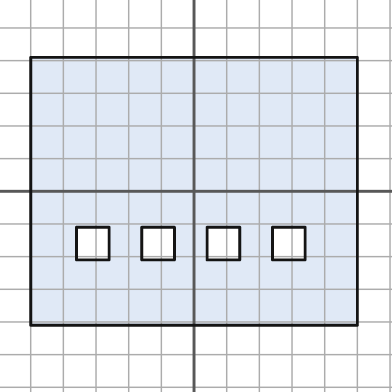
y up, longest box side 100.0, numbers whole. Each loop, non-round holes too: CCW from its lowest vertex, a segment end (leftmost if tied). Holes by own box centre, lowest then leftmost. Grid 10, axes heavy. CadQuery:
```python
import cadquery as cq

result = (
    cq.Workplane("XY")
    .moveTo(-50.0, -41.0)
    .lineTo(50.0, -41.0)
    .lineTo(50.0, 41.0)
    .lineTo(-50.0, 41.0)
    .close()
    .moveTo(-36.0, -21.0)
    .lineTo(-26.0, -21.0)
    .lineTo(-26.0, -11.0)
    .lineTo(-36.0, -11.0)
    .close()
    .moveTo(-16.0, -21.0)
    .lineTo(-6.0, -21.0)
    .lineTo(-6.0, -11.0)
    .lineTo(-16.0, -11.0)
    .close()
    .moveTo(4.0, -21.0)
    .lineTo(14.0, -21.0)
    .lineTo(14.0, -11.0)
    .lineTo(4.0, -11.0)
    .close()
    .moveTo(24.0, -21.0)
    .lineTo(34.0, -21.0)
    .lineTo(34.0, -11.0)
    .lineTo(24.0, -11.0)
    .close()
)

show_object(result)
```